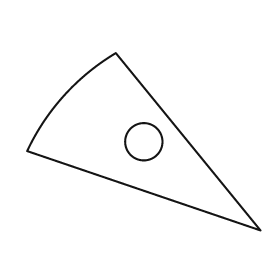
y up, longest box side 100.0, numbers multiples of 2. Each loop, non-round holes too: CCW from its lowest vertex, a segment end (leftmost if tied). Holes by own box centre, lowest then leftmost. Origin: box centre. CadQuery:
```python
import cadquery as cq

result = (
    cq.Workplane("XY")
    .moveTo(50.0, -38.0)
    .lineTo(-12.0, 38.0)
    .threePointArc((-34.0, 20.0), (-50.0, -4.0))
    .close()
    .moveTo(0.0, 0.0)
    .circle(8.0)
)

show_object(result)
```